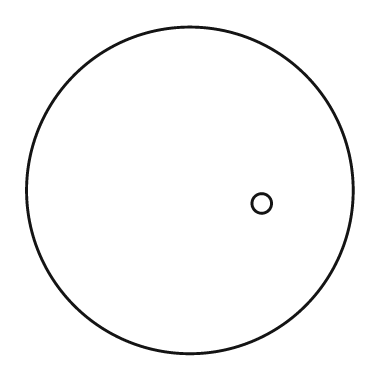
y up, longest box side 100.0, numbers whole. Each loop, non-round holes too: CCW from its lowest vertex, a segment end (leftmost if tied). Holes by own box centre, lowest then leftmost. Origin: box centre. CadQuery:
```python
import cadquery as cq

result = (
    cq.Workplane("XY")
    .moveTo(0.0, 0.0)
    .circle(50.0)
    .moveTo(22.0, -4.0)
    .circle(3.0)
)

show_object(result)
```